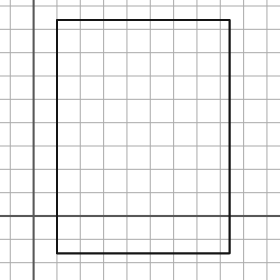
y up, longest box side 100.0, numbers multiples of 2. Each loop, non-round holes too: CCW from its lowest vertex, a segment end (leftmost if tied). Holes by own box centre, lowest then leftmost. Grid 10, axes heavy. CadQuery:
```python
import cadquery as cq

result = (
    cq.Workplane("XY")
    .moveTo(10.0, -16.0)
    .lineTo(84.0, -16.0)
    .lineTo(84.0, 84.0)
    .lineTo(10.0, 84.0)
    .close()
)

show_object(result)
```